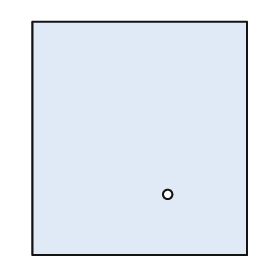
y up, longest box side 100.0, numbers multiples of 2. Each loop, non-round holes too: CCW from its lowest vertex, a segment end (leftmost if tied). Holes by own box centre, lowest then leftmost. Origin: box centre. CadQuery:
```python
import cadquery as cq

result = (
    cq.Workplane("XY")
    .moveTo(-46.0, -50.0)
    .lineTo(46.0, -50.0)
    .lineTo(46.0, 50.0)
    .lineTo(-46.0, 50.0)
    .close()
    .moveTo(12.0, -24.0)
    .circle(2.0)
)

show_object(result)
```